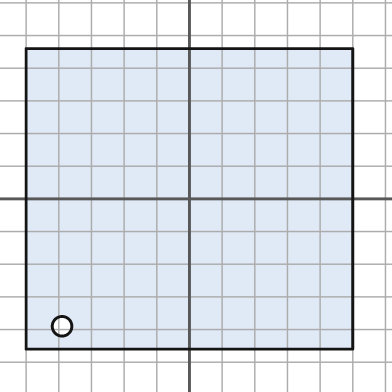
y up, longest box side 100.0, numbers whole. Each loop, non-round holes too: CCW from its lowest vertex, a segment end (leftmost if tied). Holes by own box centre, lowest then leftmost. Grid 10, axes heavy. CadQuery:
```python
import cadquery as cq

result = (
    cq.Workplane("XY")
    .moveTo(-50.0, -46.0)
    .lineTo(50.0, -46.0)
    .lineTo(50.0, 46.0)
    .lineTo(-50.0, 46.0)
    .close()
    .moveTo(-39.0, -39.0)
    .circle(3.0)
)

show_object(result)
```